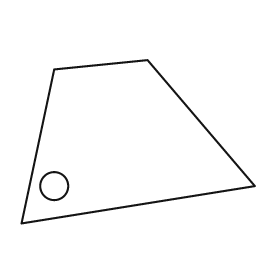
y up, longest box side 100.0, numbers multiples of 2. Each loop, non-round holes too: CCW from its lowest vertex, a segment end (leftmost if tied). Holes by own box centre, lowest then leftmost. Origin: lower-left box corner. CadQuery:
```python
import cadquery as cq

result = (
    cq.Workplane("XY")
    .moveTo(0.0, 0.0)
    .lineTo(100.0, 16.0)
    .lineTo(54.0, 70.0)
    .lineTo(14.0, 66.0)
    .close()
    .moveTo(14.0, 16.0)
    .circle(6.0)
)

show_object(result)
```